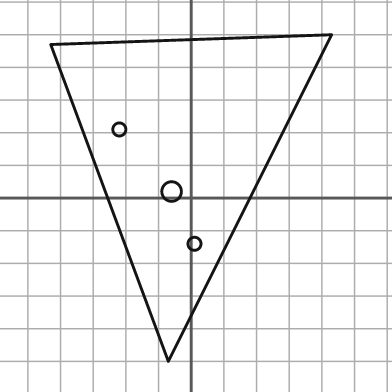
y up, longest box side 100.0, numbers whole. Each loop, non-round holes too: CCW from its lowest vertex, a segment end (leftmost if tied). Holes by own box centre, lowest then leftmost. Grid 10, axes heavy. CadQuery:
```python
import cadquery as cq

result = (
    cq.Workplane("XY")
    .moveTo(-7.0, -50.0)
    .lineTo(43.0, 50.0)
    .lineTo(-43.0, 47.0)
    .close()
    .moveTo(1.0, -14.0)
    .circle(2.0)
    .moveTo(-6.0, 2.0)
    .circle(3.0)
    .moveTo(-22.0, 21.0)
    .circle(2.0)
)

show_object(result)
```